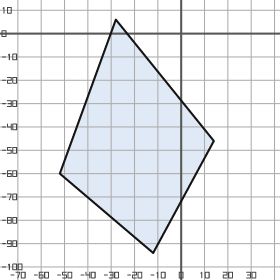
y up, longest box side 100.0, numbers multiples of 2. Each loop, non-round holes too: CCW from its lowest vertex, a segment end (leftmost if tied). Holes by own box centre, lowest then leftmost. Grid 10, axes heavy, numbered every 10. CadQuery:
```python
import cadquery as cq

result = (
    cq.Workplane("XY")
    .moveTo(-12.0, -94.0)
    .lineTo(14.0, -46.0)
    .lineTo(-28.0, 6.0)
    .lineTo(-52.0, -60.0)
    .close()
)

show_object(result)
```